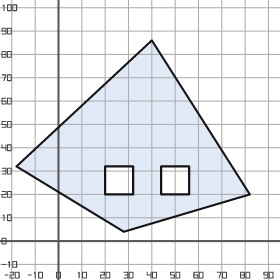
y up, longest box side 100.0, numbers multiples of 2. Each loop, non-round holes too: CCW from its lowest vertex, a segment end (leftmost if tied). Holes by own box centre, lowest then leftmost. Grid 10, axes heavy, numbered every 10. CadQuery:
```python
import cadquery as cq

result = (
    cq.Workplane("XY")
    .moveTo(28.0, 4.0)
    .lineTo(82.0, 20.0)
    .lineTo(40.0, 86.0)
    .lineTo(-18.0, 32.0)
    .close()
    .moveTo(20.0, 20.0)
    .lineTo(32.0, 20.0)
    .lineTo(32.0, 32.0)
    .lineTo(20.0, 32.0)
    .close()
    .moveTo(44.0, 20.0)
    .lineTo(56.0, 20.0)
    .lineTo(56.0, 32.0)
    .lineTo(44.0, 32.0)
    .close()
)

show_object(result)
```